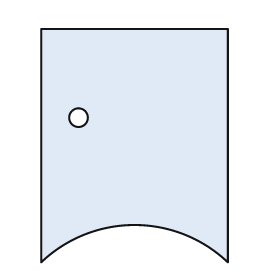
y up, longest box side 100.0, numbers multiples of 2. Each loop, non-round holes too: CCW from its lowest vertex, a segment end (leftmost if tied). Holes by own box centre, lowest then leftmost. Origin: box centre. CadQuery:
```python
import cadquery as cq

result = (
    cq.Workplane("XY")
    .moveTo(-40.0, -50.0)
    .threePointArc((0.0, -34.0), (40.0, -50.0))
    .lineTo(40.0, 50.0)
    .lineTo(-40.0, 50.0)
    .close()
    .moveTo(-24.0, 12.0)
    .circle(4.0)
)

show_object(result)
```